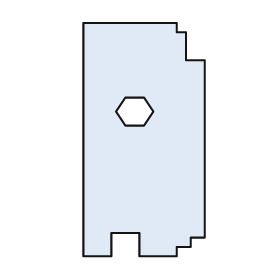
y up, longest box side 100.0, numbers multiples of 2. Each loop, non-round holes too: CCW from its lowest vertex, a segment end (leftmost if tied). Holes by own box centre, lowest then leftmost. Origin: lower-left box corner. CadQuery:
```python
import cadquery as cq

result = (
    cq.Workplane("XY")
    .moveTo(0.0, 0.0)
    .lineTo(12.0, 0.0)
    .lineTo(12.0, 10.0)
    .lineTo(24.0, 10.0)
    .lineTo(24.0, 0.0)
    .lineTo(40.0, 0.0)
    .lineTo(40.0, 4.0)
    .lineTo(46.0, 4.0)
    .lineTo(46.0, 8.0)
    .lineTo(52.0, 8.0)
    .lineTo(52.0, 84.0)
    .lineTo(44.0, 84.0)
    .lineTo(44.0, 96.0)
    .lineTo(40.0, 96.0)
    .lineTo(40.0, 100.0)
    .lineTo(0.0, 100.0)
    .close()
    .moveTo(18.0, 56.0)
    .lineTo(26.0, 56.0)
    .lineTo(30.0, 62.0)
    .lineTo(26.0, 68.0)
    .lineTo(18.0, 68.0)
    .lineTo(14.0, 62.0)
    .close()
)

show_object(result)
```